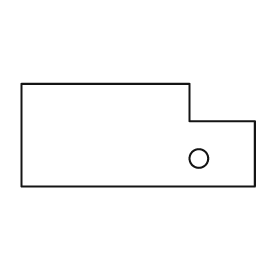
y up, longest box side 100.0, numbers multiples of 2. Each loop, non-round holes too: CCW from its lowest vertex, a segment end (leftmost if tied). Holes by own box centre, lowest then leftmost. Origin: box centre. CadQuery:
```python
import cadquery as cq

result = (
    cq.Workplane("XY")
    .moveTo(-50.0, -22.0)
    .lineTo(50.0, -22.0)
    .lineTo(50.0, 6.0)
    .lineTo(22.0, 6.0)
    .lineTo(22.0, 22.0)
    .lineTo(-50.0, 22.0)
    .close()
    .moveTo(26.0, -10.0)
    .circle(4.0)
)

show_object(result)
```